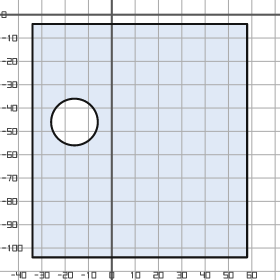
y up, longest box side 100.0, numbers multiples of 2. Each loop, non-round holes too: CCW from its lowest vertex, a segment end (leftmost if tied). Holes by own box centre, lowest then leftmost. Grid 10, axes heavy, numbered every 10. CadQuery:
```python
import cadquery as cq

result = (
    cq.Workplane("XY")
    .moveTo(-34.0, -104.0)
    .lineTo(58.0, -104.0)
    .lineTo(58.0, -4.0)
    .lineTo(-34.0, -4.0)
    .close()
    .moveTo(-16.0, -46.0)
    .circle(10.0)
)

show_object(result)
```